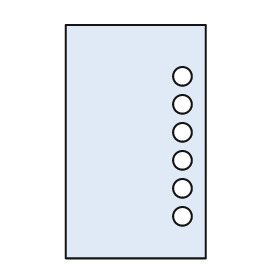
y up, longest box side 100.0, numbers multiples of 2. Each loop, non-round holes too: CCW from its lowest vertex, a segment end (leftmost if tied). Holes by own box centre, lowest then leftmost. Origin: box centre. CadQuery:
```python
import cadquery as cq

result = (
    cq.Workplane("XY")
    .moveTo(-30.0, -50.0)
    .lineTo(30.0, -50.0)
    .lineTo(30.0, 50.0)
    .lineTo(-30.0, 50.0)
    .close()
    .moveTo(20.0, -32.0)
    .circle(4.0)
    .moveTo(20.0, -20.0)
    .circle(4.0)
    .moveTo(20.0, -8.0)
    .circle(4.0)
    .moveTo(20.0, 4.0)
    .circle(4.0)
    .moveTo(20.0, 16.0)
    .circle(4.0)
    .moveTo(20.0, 28.0)
    .circle(4.0)
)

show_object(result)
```